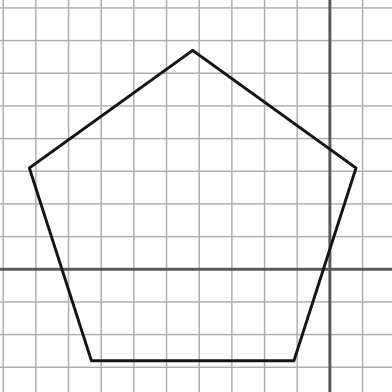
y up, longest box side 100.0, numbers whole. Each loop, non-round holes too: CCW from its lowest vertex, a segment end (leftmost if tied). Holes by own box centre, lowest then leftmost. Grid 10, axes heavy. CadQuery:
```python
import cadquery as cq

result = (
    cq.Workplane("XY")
    .moveTo(-73.0, -28.0)
    .lineTo(-11.0, -28.0)
    .lineTo(8.0, 31.0)
    .lineTo(-42.0, 67.0)
    .lineTo(-92.0, 31.0)
    .close()
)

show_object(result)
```